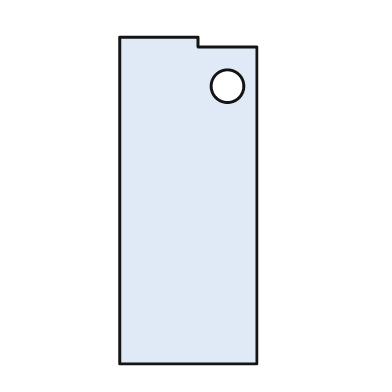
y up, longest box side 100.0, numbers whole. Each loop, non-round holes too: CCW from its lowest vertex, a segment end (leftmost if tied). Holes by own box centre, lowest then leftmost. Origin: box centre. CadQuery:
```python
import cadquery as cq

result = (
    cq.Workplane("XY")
    .moveTo(-21.0, -50.0)
    .lineTo(21.0, -50.0)
    .lineTo(21.0, 47.0)
    .lineTo(3.0, 47.0)
    .lineTo(3.0, 50.0)
    .lineTo(-21.0, 50.0)
    .close()
    .moveTo(12.0, 35.0)
    .circle(5.0)
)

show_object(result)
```